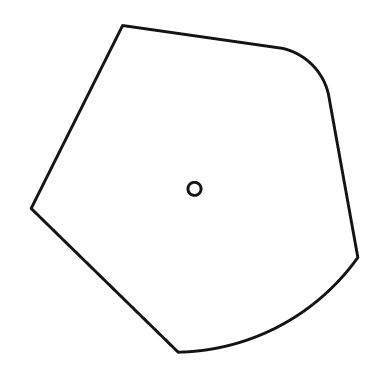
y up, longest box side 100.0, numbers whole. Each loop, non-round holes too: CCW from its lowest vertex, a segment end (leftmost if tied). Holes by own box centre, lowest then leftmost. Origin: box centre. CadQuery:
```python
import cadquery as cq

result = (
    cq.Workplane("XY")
    .moveTo(-5.0, -50.0)
    .threePointArc((26.0, -42.0), (50.0, -21.0))
    .lineTo(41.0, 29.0)
    .threePointArc((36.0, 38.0), (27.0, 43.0))
    .lineTo(-22.0, 50.0)
    .lineTo(-50.0, -6.0)
    .close()
    .moveTo(0.0, 0.0)
    .circle(2.0)
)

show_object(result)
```